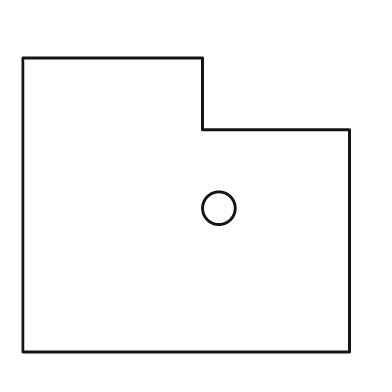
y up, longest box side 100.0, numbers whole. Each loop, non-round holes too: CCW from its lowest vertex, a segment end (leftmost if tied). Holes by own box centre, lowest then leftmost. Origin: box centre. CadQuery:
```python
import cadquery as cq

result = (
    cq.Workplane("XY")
    .moveTo(-50.0, -45.0)
    .lineTo(50.0, -45.0)
    .lineTo(50.0, 23.0)
    .lineTo(5.0, 23.0)
    .lineTo(5.0, 45.0)
    .lineTo(-50.0, 45.0)
    .close()
    .moveTo(10.0, -1.0)
    .circle(5.0)
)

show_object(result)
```